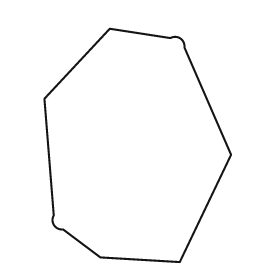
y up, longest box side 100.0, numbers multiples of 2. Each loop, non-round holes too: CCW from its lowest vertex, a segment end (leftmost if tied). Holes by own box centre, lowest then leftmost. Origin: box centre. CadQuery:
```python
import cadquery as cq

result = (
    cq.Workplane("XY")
    .moveTo(18.0, -50.0)
    .lineTo(40.0, -4.0)
    .lineTo(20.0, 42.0)
    .threePointArc((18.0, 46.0), (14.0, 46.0))
    .lineTo(-12.0, 50.0)
    .lineTo(-40.0, 20.0)
    .lineTo(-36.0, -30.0)
    .threePointArc((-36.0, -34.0), (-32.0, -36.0))
    .lineTo(-16.0, -48.0)
    .close()
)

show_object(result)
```